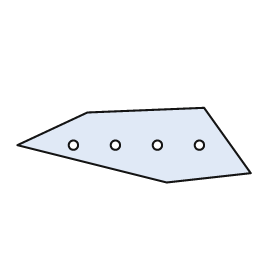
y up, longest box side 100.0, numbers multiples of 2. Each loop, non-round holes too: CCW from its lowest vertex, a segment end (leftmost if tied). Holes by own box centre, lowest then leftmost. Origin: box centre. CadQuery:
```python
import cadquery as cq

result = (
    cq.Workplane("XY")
    .moveTo(14.0, -16.0)
    .lineTo(50.0, -12.0)
    .lineTo(30.0, 16.0)
    .lineTo(-20.0, 14.0)
    .lineTo(-50.0, 0.0)
    .close()
    .moveTo(-26.0, 0.0)
    .circle(2.0)
    .moveTo(-8.0, 0.0)
    .circle(2.0)
    .moveTo(10.0, 0.0)
    .circle(2.0)
    .moveTo(28.0, 0.0)
    .circle(2.0)
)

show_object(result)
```